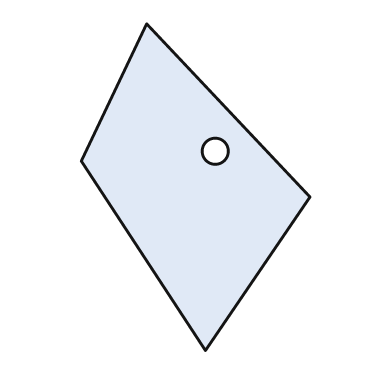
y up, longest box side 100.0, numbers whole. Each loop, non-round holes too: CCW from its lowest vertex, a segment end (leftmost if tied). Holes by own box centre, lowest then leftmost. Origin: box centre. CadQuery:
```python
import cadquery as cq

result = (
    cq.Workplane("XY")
    .moveTo(3.0, -50.0)
    .lineTo(35.0, -3.0)
    .lineTo(-15.0, 50.0)
    .lineTo(-35.0, 8.0)
    .close()
    .moveTo(6.0, 11.0)
    .circle(4.0)
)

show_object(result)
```